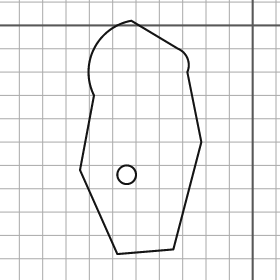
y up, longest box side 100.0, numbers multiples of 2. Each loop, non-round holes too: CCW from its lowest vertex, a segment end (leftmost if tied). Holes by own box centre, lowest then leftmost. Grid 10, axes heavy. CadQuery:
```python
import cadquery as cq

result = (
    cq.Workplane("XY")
    .moveTo(-58.0, -98.0)
    .lineTo(-34.0, -96.0)
    .lineTo(-22.0, -50.0)
    .lineTo(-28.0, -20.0)
    .threePointArc((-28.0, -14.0), (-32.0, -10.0))
    .lineTo(-52.0, 2.0)
    .threePointArc((-68.0, -10.0), (-68.0, -30.0))
    .lineTo(-74.0, -62.0)
    .close()
    .moveTo(-54.0, -64.0)
    .circle(4.0)
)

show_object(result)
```